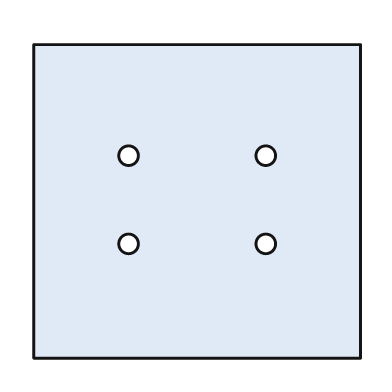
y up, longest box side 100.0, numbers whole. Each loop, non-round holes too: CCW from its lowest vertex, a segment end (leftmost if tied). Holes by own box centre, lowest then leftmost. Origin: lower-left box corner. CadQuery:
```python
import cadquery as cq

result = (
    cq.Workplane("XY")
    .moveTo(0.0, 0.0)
    .lineTo(100.0, 0.0)
    .lineTo(100.0, 96.0)
    .lineTo(0.0, 96.0)
    .close()
    .moveTo(29.0, 35.0)
    .circle(3.0)
    .moveTo(71.0, 35.0)
    .circle(3.0)
    .moveTo(29.0, 62.0)
    .circle(3.0)
    .moveTo(71.0, 62.0)
    .circle(3.0)
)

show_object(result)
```